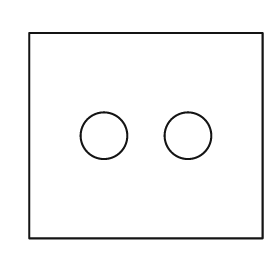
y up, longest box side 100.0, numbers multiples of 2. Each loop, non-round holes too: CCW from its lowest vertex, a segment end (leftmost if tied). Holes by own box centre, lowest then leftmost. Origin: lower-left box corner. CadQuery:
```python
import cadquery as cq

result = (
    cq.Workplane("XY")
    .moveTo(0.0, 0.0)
    .lineTo(100.0, 0.0)
    .lineTo(100.0, 88.0)
    .lineTo(0.0, 88.0)
    .close()
    .moveTo(32.0, 44.0)
    .circle(10.0)
    .moveTo(68.0, 44.0)
    .circle(10.0)
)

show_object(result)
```